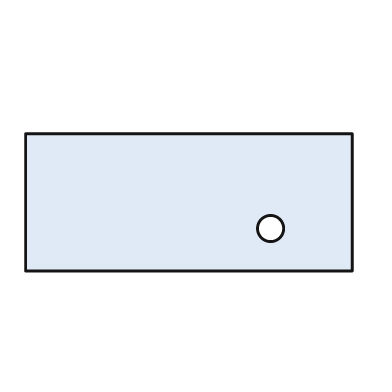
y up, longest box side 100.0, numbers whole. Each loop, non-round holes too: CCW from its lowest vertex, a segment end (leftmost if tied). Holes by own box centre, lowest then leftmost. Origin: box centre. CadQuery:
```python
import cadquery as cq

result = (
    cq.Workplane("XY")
    .moveTo(-50.0, -21.0)
    .lineTo(50.0, -21.0)
    .lineTo(50.0, 21.0)
    .lineTo(-50.0, 21.0)
    .close()
    .moveTo(25.0, -8.0)
    .circle(4.0)
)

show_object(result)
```